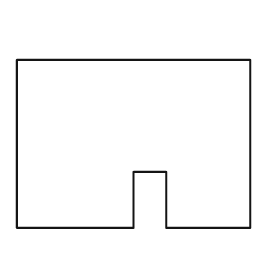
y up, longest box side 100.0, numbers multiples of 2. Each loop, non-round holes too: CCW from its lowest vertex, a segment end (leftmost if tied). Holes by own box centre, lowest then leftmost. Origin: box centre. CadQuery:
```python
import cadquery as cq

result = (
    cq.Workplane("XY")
    .moveTo(-50.0, -36.0)
    .lineTo(0.0, -36.0)
    .lineTo(0.0, -12.0)
    .lineTo(14.0, -12.0)
    .lineTo(14.0, -36.0)
    .lineTo(50.0, -36.0)
    .lineTo(50.0, 36.0)
    .lineTo(-50.0, 36.0)
    .close()
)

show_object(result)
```